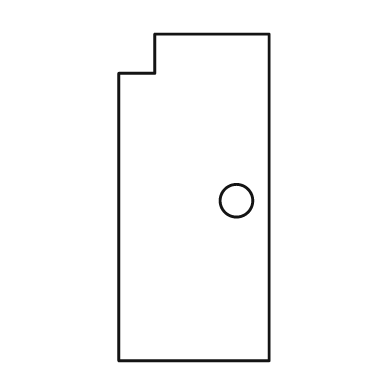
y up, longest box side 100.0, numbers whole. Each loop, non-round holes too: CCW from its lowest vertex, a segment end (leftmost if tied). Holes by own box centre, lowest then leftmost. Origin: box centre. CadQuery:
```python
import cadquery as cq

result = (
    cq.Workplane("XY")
    .moveTo(-23.0, -50.0)
    .lineTo(23.0, -50.0)
    .lineTo(23.0, 50.0)
    .lineTo(-12.0, 50.0)
    .lineTo(-12.0, 38.0)
    .lineTo(-23.0, 38.0)
    .close()
    .moveTo(13.0, -1.0)
    .circle(5.0)
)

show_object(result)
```